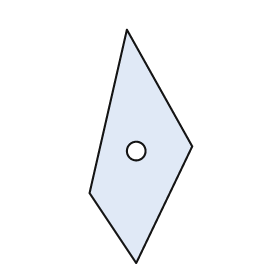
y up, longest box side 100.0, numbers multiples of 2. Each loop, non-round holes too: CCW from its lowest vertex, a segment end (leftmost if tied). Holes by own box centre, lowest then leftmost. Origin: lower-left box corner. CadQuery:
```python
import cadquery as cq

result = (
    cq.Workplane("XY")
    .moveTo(20.0, 0.0)
    .lineTo(44.0, 50.0)
    .lineTo(16.0, 100.0)
    .lineTo(0.0, 30.0)
    .close()
    .moveTo(20.0, 48.0)
    .circle(4.0)
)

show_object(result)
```